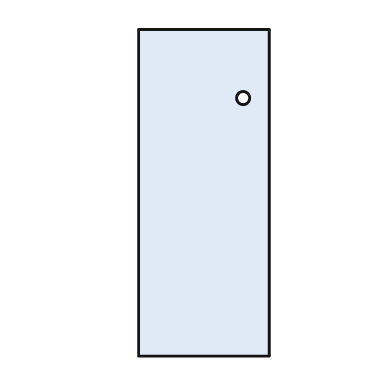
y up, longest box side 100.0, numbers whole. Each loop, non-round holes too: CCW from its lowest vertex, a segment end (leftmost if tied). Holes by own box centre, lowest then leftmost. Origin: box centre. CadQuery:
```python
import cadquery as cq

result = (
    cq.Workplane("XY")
    .moveTo(-20.0, -50.0)
    .lineTo(20.0, -50.0)
    .lineTo(20.0, 50.0)
    .lineTo(-20.0, 50.0)
    .close()
    .moveTo(12.0, 29.0)
    .circle(2.0)
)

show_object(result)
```